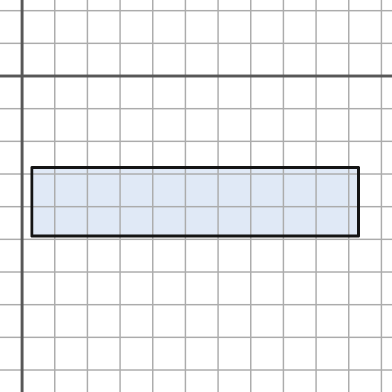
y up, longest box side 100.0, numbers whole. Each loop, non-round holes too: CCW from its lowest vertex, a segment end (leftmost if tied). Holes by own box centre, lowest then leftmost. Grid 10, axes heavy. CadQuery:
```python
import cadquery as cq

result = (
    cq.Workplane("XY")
    .moveTo(3.0, -49.0)
    .lineTo(103.0, -49.0)
    .lineTo(103.0, -28.0)
    .lineTo(3.0, -28.0)
    .close()
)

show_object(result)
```